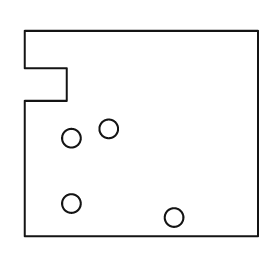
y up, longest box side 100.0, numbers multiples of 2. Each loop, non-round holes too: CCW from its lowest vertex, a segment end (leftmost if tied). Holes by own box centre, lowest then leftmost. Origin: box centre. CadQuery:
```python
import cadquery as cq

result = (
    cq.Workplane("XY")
    .moveTo(-50.0, -44.0)
    .lineTo(50.0, -44.0)
    .lineTo(50.0, 44.0)
    .lineTo(-50.0, 44.0)
    .lineTo(-50.0, 28.0)
    .lineTo(-32.0, 28.0)
    .lineTo(-32.0, 14.0)
    .lineTo(-50.0, 14.0)
    .close()
    .moveTo(14.0, -36.0)
    .circle(4.0)
    .moveTo(-30.0, -30.0)
    .circle(4.0)
    .moveTo(-30.0, -2.0)
    .circle(4.0)
    .moveTo(-14.0, 2.0)
    .circle(4.0)
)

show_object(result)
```